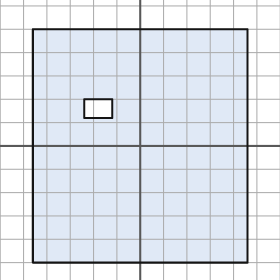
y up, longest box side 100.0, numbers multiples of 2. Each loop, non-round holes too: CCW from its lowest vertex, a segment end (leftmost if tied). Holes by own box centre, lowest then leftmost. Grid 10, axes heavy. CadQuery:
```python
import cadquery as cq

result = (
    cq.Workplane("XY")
    .moveTo(-46.0, -50.0)
    .lineTo(46.0, -50.0)
    .lineTo(46.0, 50.0)
    .lineTo(-46.0, 50.0)
    .close()
    .moveTo(-24.0, 12.0)
    .lineTo(-12.0, 12.0)
    .lineTo(-12.0, 20.0)
    .lineTo(-24.0, 20.0)
    .close()
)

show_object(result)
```